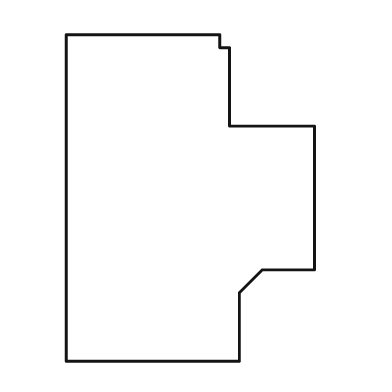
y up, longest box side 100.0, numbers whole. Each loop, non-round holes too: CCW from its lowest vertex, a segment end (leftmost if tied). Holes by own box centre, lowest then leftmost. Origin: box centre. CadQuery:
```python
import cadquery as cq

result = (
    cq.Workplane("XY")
    .moveTo(-38.0, -50.0)
    .lineTo(15.0, -50.0)
    .lineTo(15.0, -29.0)
    .lineTo(22.0, -22.0)
    .lineTo(38.0, -22.0)
    .lineTo(38.0, 22.0)
    .lineTo(12.0, 22.0)
    .lineTo(12.0, 46.0)
    .lineTo(9.0, 46.0)
    .lineTo(9.0, 50.0)
    .lineTo(-38.0, 50.0)
    .close()
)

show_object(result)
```